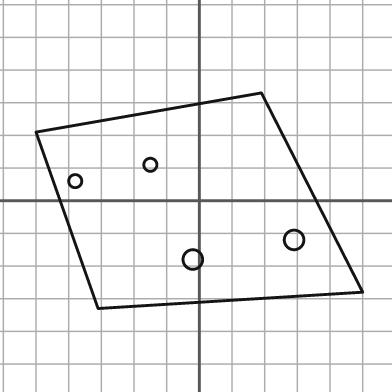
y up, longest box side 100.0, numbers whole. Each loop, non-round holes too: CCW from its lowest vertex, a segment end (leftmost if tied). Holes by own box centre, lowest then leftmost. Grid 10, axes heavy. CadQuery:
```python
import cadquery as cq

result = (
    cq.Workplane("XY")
    .moveTo(-31.0, -33.0)
    .lineTo(50.0, -28.0)
    .lineTo(19.0, 33.0)
    .lineTo(-50.0, 21.0)
    .close()
    .moveTo(-2.0, -18.0)
    .circle(3.0)
    .moveTo(29.0, -12.0)
    .circle(3.0)
    .moveTo(-38.0, 6.0)
    .circle(2.0)
    .moveTo(-15.0, 11.0)
    .circle(2.0)
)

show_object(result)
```